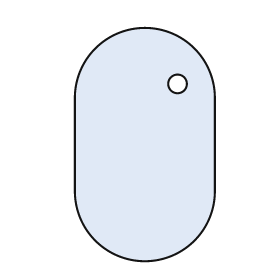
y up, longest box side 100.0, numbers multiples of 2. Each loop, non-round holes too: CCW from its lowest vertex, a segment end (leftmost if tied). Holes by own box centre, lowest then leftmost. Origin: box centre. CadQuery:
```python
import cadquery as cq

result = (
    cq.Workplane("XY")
    .moveTo(-30.0, -20.0)
    .threePointArc((0.0, -50.0), (30.0, -20.0))
    .lineTo(30.0, 20.0)
    .threePointArc((0.0, 50.0), (-30.0, 20.0))
    .close()
    .moveTo(14.0, 26.0)
    .circle(4.0)
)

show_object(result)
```